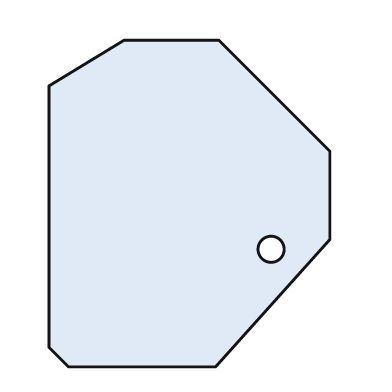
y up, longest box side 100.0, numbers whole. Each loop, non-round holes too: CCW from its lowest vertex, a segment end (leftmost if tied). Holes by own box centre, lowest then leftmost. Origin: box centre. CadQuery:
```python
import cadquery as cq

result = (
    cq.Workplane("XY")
    .moveTo(-37.0, -50.0)
    .lineTo(8.0, -50.0)
    .lineTo(43.0, -11.0)
    .lineTo(43.0, 16.0)
    .lineTo(9.0, 50.0)
    .lineTo(-20.0, 50.0)
    .lineTo(-43.0, 36.0)
    .lineTo(-43.0, -44.0)
    .close()
    .moveTo(25.0, -14.0)
    .circle(4.0)
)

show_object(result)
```